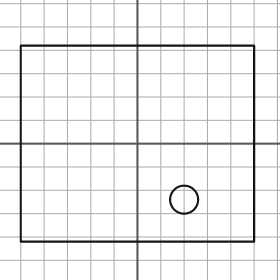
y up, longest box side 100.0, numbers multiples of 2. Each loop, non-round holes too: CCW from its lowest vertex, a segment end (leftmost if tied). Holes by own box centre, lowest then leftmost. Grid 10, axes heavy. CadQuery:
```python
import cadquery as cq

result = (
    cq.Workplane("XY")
    .moveTo(-50.0, -42.0)
    .lineTo(50.0, -42.0)
    .lineTo(50.0, 42.0)
    .lineTo(-50.0, 42.0)
    .close()
    .moveTo(20.0, -24.0)
    .circle(6.0)
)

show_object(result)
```